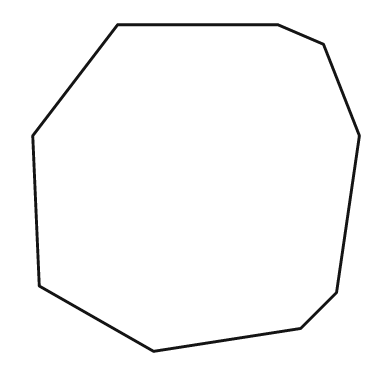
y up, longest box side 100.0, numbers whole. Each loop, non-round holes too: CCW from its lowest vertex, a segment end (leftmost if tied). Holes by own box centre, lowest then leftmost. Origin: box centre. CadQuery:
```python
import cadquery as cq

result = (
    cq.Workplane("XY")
    .moveTo(-13.0, -50.0)
    .lineTo(32.0, -43.0)
    .lineTo(43.0, -32.0)
    .lineTo(50.0, 16.0)
    .lineTo(39.0, 44.0)
    .lineTo(25.0, 50.0)
    .lineTo(-24.0, 50.0)
    .lineTo(-50.0, 16.0)
    .lineTo(-48.0, -30.0)
    .close()
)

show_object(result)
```